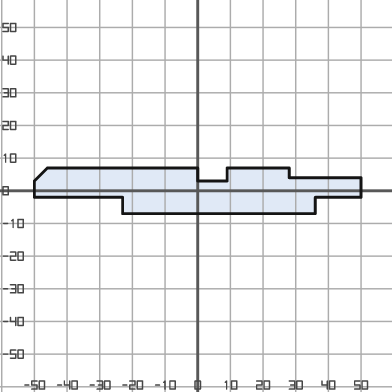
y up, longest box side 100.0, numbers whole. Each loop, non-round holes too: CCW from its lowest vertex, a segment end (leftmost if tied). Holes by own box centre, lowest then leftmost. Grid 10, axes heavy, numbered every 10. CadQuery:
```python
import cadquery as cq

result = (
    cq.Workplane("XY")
    .moveTo(-23.0, -7.0)
    .lineTo(36.0, -7.0)
    .lineTo(36.0, -2.0)
    .lineTo(50.0, -2.0)
    .lineTo(50.0, 4.0)
    .lineTo(28.0, 4.0)
    .lineTo(28.0, 7.0)
    .lineTo(9.0, 7.0)
    .lineTo(9.0, 3.0)
    .lineTo(0.0, 3.0)
    .lineTo(0.0, 7.0)
    .lineTo(-46.0, 7.0)
    .lineTo(-50.0, 3.0)
    .lineTo(-50.0, -2.0)
    .lineTo(-23.0, -2.0)
    .close()
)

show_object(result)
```